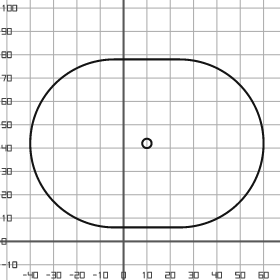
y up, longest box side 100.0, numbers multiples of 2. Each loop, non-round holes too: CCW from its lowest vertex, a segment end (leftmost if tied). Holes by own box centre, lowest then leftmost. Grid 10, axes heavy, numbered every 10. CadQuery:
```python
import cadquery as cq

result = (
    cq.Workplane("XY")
    .moveTo(-4.0, 6.0)
    .lineTo(24.0, 6.0)
    .threePointArc((60.0, 42.0), (24.0, 78.0))
    .lineTo(-4.0, 78.0)
    .threePointArc((-40.0, 42.0), (-4.0, 6.0))
    .close()
    .moveTo(10.0, 42.0)
    .circle(2.0)
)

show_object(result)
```